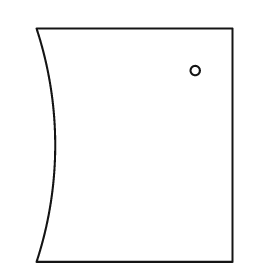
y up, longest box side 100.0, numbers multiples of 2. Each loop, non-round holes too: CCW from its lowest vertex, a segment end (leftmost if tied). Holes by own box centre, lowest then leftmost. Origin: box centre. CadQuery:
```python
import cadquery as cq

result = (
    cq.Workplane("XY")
    .moveTo(-42.0, -50.0)
    .lineTo(42.0, -50.0)
    .lineTo(42.0, 50.0)
    .lineTo(-42.0, 50.0)
    .threePointArc((-34.0, 0.0), (-42.0, -50.0))
    .close()
    .moveTo(26.0, 32.0)
    .circle(2.0)
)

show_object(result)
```